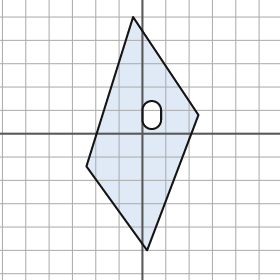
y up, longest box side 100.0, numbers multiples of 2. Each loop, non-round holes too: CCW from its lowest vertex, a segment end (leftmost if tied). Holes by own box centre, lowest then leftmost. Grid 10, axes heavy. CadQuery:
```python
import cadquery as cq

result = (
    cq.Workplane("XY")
    .moveTo(2.0, -50.0)
    .lineTo(24.0, 8.0)
    .lineTo(-4.0, 50.0)
    .lineTo(-24.0, -14.0)
    .close()
    .moveTo(0.0, 6.0)
    .threePointArc((4.0, 2.0), (8.0, 6.0))
    .lineTo(8.0, 10.0)
    .threePointArc((4.0, 14.0), (0.0, 10.0))
    .close()
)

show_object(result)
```